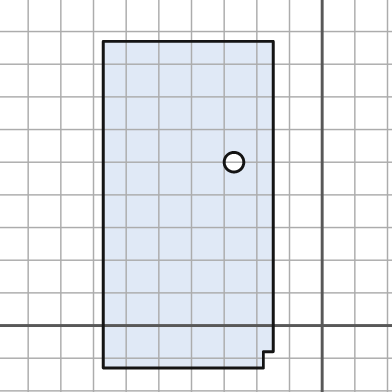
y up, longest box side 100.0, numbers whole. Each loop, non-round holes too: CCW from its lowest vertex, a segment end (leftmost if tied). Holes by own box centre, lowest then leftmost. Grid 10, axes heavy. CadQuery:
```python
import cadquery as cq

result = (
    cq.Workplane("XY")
    .moveTo(-67.0, -13.0)
    .lineTo(-18.0, -13.0)
    .lineTo(-18.0, -8.0)
    .lineTo(-15.0, -8.0)
    .lineTo(-15.0, 87.0)
    .lineTo(-67.0, 87.0)
    .close()
    .moveTo(-27.0, 50.0)
    .circle(3.0)
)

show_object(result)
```